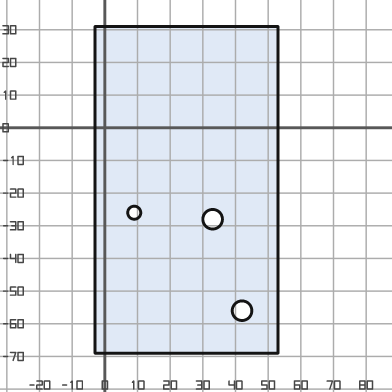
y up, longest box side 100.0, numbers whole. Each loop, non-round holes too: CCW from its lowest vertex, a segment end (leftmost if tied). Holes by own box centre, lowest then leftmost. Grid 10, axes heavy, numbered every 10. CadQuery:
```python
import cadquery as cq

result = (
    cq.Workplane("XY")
    .moveTo(-3.0, -69.0)
    .lineTo(53.0, -69.0)
    .lineTo(53.0, 31.0)
    .lineTo(-3.0, 31.0)
    .close()
    .moveTo(42.0, -56.0)
    .circle(3.0)
    .moveTo(33.0, -28.0)
    .circle(3.0)
    .moveTo(9.0, -26.0)
    .circle(2.0)
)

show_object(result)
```